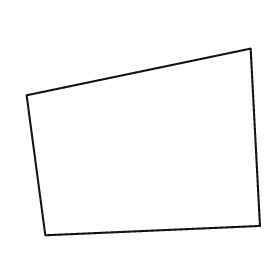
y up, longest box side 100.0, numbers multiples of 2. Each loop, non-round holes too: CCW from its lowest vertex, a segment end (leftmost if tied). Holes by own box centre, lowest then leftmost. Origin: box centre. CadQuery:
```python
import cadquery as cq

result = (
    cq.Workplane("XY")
    .moveTo(-42.0, -40.0)
    .lineTo(50.0, -36.0)
    .lineTo(46.0, 40.0)
    .lineTo(-50.0, 20.0)
    .close()
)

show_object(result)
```